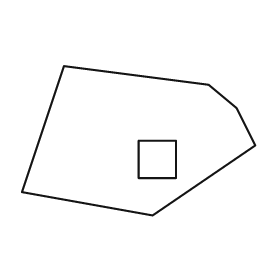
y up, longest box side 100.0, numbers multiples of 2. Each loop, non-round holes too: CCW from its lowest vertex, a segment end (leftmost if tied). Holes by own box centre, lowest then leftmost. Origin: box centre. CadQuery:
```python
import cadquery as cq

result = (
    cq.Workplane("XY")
    .moveTo(6.0, -32.0)
    .lineTo(50.0, -2.0)
    .lineTo(42.0, 14.0)
    .lineTo(30.0, 24.0)
    .lineTo(-32.0, 32.0)
    .lineTo(-50.0, -22.0)
    .close()
    .moveTo(0.0, -16.0)
    .lineTo(16.0, -16.0)
    .lineTo(16.0, 0.0)
    .lineTo(0.0, 0.0)
    .close()
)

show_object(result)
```